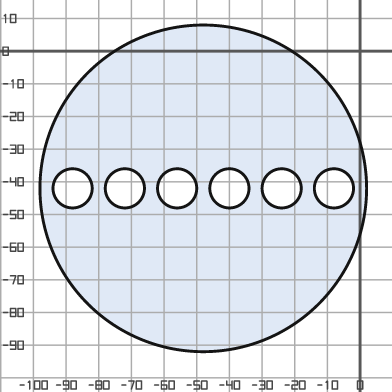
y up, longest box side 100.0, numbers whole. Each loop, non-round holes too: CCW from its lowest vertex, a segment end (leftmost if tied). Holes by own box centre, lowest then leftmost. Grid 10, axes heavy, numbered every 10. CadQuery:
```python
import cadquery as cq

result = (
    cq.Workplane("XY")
    .moveTo(-48.0, -42.0)
    .circle(50.0)
    .moveTo(-88.0, -42.0)
    .circle(6.0)
    .moveTo(-72.0, -42.0)
    .circle(6.0)
    .moveTo(-56.0, -42.0)
    .circle(6.0)
    .moveTo(-40.0, -42.0)
    .circle(6.0)
    .moveTo(-24.0, -42.0)
    .circle(6.0)
    .moveTo(-8.0, -42.0)
    .circle(6.0)
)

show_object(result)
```